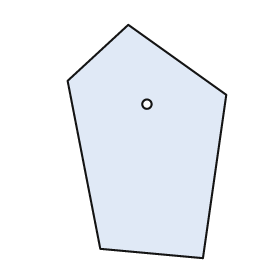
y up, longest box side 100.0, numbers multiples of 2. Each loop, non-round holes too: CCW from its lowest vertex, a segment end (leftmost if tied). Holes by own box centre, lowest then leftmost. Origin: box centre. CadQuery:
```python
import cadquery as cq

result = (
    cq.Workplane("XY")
    .moveTo(24.0, -50.0)
    .lineTo(34.0, 20.0)
    .lineTo(-8.0, 50.0)
    .lineTo(-34.0, 26.0)
    .lineTo(-20.0, -46.0)
    .close()
    .moveTo(0.0, 16.0)
    .circle(2.0)
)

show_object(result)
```